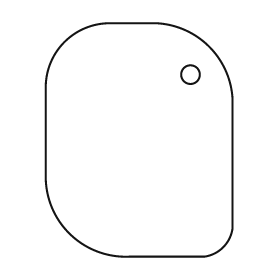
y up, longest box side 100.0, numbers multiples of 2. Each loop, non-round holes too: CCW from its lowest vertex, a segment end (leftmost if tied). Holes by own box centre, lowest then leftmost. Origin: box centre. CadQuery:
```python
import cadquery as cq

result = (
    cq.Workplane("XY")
    .moveTo(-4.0, -50.0)
    .lineTo(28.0, -50.0)
    .threePointArc((36.0, -46.0), (40.0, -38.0))
    .lineTo(40.0, 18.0)
    .threePointArc((30.0, 40.0), (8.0, 50.0))
    .lineTo(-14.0, 50.0)
    .threePointArc((-32.0, 42.0), (-40.0, 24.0))
    .lineTo(-40.0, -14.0)
    .threePointArc((-30.0, -40.0), (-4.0, -50.0))
    .close()
    .moveTo(22.0, 28.0)
    .circle(4.0)
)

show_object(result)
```